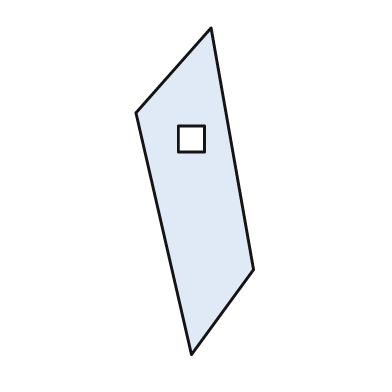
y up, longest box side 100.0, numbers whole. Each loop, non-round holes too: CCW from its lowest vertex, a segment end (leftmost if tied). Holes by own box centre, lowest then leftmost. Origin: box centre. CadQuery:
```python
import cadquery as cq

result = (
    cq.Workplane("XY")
    .moveTo(-1.0, -50.0)
    .lineTo(18.0, -24.0)
    .lineTo(5.0, 50.0)
    .lineTo(-18.0, 24.0)
    .close()
    .moveTo(-5.0, 12.0)
    .lineTo(3.0, 12.0)
    .lineTo(3.0, 20.0)
    .lineTo(-5.0, 20.0)
    .close()
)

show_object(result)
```